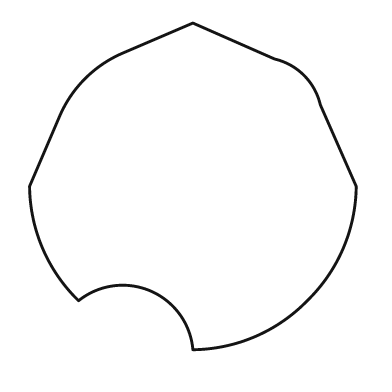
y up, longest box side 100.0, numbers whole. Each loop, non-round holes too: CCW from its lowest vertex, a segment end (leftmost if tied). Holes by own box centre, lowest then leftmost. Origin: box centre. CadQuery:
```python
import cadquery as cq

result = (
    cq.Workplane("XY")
    .moveTo(0.0, -50.0)
    .threePointArc((19.0, -46.0), (35.0, -35.0))
    .threePointArc((46.0, -19.0), (50.0, 0.0))
    .lineTo(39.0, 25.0)
    .threePointArc((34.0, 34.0), (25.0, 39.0))
    .lineTo(0.0, 50.0)
    .lineTo(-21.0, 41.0)
    .threePointArc((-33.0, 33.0), (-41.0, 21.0))
    .lineTo(-50.0, 0.0)
    .threePointArc((-46.0, -19.0), (-35.0, -35.0))
    .threePointArc((-13.0, -32.0), (0.0, -50.0))
    .close()
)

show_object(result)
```